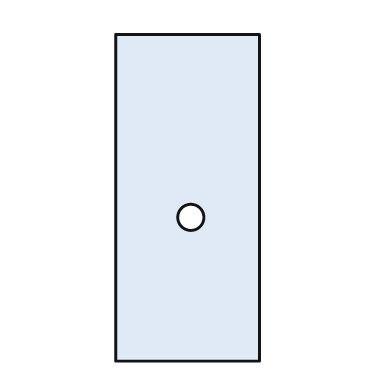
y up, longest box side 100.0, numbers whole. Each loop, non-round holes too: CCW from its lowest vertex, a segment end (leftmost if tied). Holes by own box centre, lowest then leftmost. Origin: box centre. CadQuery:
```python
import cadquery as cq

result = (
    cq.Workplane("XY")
    .moveTo(-22.0, -50.0)
    .lineTo(22.0, -50.0)
    .lineTo(22.0, 50.0)
    .lineTo(-22.0, 50.0)
    .close()
    .moveTo(1.0, -6.0)
    .circle(4.0)
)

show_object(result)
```